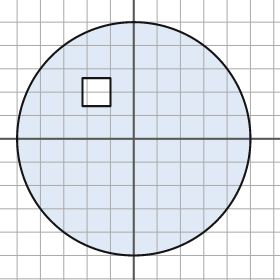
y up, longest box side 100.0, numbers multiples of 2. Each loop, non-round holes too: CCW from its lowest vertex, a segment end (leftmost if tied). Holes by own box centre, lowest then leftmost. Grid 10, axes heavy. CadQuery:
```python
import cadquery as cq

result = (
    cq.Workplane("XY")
    .moveTo(0.0, 0.0)
    .circle(50.0)
    .moveTo(-22.0, 14.0)
    .lineTo(-10.0, 14.0)
    .lineTo(-10.0, 26.0)
    .lineTo(-22.0, 26.0)
    .close()
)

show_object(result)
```